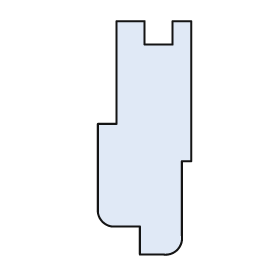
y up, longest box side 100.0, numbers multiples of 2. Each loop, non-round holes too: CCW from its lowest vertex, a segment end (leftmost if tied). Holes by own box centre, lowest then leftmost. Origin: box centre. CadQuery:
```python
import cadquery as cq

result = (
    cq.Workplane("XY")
    .moveTo(-2.0, -50.0)
    .lineTo(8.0, -50.0)
    .threePointArc((14.0, -48.0), (16.0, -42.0))
    .lineTo(16.0, -10.0)
    .lineTo(20.0, -10.0)
    .lineTo(20.0, 50.0)
    .lineTo(12.0, 50.0)
    .lineTo(12.0, 40.0)
    .lineTo(0.0, 40.0)
    .lineTo(0.0, 50.0)
    .lineTo(-12.0, 50.0)
    .lineTo(-12.0, 6.0)
    .lineTo(-20.0, 6.0)
    .lineTo(-20.0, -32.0)
    .threePointArc((-18.0, -36.0), (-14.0, -38.0))
    .lineTo(-2.0, -38.0)
    .close()
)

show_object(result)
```